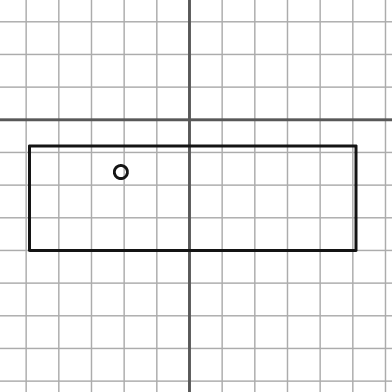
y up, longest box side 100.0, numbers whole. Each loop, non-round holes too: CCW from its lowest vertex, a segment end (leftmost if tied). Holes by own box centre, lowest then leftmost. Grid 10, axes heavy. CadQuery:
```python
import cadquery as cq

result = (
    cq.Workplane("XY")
    .moveTo(-49.0, -40.0)
    .lineTo(51.0, -40.0)
    .lineTo(51.0, -8.0)
    .lineTo(-49.0, -8.0)
    .close()
    .moveTo(-21.0, -16.0)
    .circle(2.0)
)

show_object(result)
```